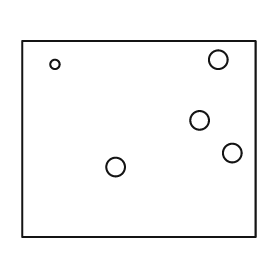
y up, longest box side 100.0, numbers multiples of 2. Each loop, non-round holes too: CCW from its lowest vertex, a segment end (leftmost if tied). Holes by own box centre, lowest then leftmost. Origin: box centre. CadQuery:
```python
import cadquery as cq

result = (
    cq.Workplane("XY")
    .moveTo(-50.0, -42.0)
    .lineTo(50.0, -42.0)
    .lineTo(50.0, 42.0)
    .lineTo(-50.0, 42.0)
    .close()
    .moveTo(-10.0, -12.0)
    .circle(4.0)
    .moveTo(40.0, -6.0)
    .circle(4.0)
    .moveTo(26.0, 8.0)
    .circle(4.0)
    .moveTo(-36.0, 32.0)
    .circle(2.0)
    .moveTo(34.0, 34.0)
    .circle(4.0)
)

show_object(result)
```